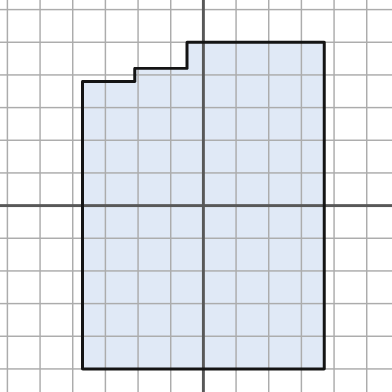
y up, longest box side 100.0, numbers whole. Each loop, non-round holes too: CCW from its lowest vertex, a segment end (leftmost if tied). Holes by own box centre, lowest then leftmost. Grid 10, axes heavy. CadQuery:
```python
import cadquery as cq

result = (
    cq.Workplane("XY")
    .moveTo(-37.0, -50.0)
    .lineTo(37.0, -50.0)
    .lineTo(37.0, 50.0)
    .lineTo(-5.0, 50.0)
    .lineTo(-5.0, 42.0)
    .lineTo(-21.0, 42.0)
    .lineTo(-21.0, 38.0)
    .lineTo(-37.0, 38.0)
    .close()
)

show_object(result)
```